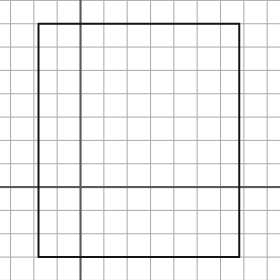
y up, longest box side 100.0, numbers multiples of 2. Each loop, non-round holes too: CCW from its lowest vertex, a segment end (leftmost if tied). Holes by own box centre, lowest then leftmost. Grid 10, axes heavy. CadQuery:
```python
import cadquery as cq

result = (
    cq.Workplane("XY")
    .moveTo(-18.0, -30.0)
    .lineTo(68.0, -30.0)
    .lineTo(68.0, 70.0)
    .lineTo(-18.0, 70.0)
    .close()
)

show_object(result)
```